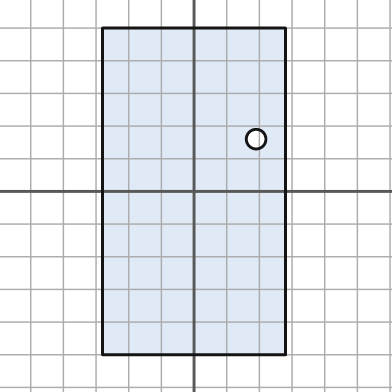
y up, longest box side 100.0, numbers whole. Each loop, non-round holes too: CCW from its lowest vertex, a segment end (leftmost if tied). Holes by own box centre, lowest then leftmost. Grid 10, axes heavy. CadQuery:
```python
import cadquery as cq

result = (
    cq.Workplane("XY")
    .moveTo(-28.0, -50.0)
    .lineTo(28.0, -50.0)
    .lineTo(28.0, 50.0)
    .lineTo(-28.0, 50.0)
    .close()
    .moveTo(19.0, 16.0)
    .circle(3.0)
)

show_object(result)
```